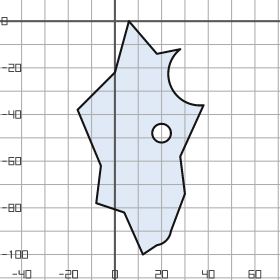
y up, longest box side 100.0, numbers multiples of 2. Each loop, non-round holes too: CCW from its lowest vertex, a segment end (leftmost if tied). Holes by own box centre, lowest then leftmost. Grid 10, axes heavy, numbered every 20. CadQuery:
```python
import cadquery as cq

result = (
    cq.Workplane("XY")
    .moveTo(12.0, -100.0)
    .lineTo(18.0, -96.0)
    .threePointArc((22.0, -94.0), (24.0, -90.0))
    .lineTo(30.0, -74.0)
    .lineTo(28.0, -58.0)
    .lineTo(38.0, -36.0)
    .threePointArc((24.0, -28.0), (28.0, -12.0))
    .lineTo(18.0, -14.0)
    .lineTo(6.0, 0.0)
    .lineTo(0.0, -22.0)
    .lineTo(-16.0, -38.0)
    .lineTo(-6.0, -62.0)
    .lineTo(-8.0, -78.0)
    .lineTo(4.0, -82.0)
    .close()
    .moveTo(20.0, -48.0)
    .circle(4.0)
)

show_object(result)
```